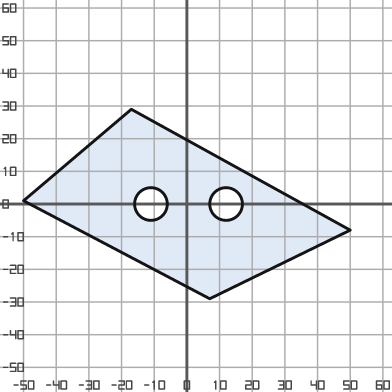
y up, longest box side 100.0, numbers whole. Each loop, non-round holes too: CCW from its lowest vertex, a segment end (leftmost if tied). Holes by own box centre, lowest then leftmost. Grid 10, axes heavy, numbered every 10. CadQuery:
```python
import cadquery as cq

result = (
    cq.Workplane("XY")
    .moveTo(7.0, -29.0)
    .lineTo(50.0, -8.0)
    .lineTo(-17.0, 29.0)
    .lineTo(-50.0, 1.0)
    .close()
    .moveTo(-11.0, 0.0)
    .circle(5.0)
    .moveTo(12.0, 0.0)
    .circle(5.0)
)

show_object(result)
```